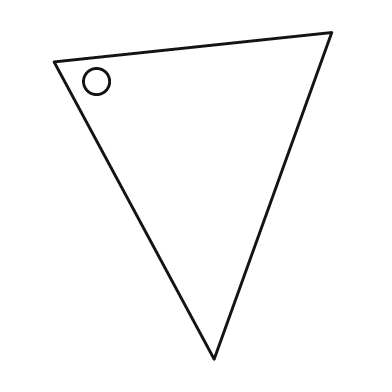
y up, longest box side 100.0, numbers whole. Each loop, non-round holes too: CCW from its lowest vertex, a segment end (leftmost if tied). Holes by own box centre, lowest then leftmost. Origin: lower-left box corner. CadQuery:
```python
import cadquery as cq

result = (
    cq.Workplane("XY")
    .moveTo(49.0, 0.0)
    .lineTo(85.0, 100.0)
    .lineTo(0.0, 91.0)
    .close()
    .moveTo(13.0, 85.0)
    .circle(4.0)
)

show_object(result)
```